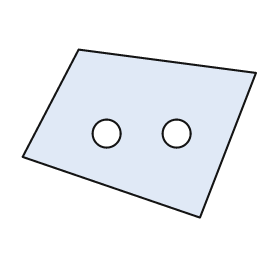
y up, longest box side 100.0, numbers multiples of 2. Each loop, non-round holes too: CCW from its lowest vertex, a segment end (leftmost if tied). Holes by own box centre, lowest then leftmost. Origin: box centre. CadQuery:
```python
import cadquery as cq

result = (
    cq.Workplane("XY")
    .moveTo(26.0, -36.0)
    .lineTo(50.0, 26.0)
    .lineTo(-26.0, 36.0)
    .lineTo(-50.0, -10.0)
    .close()
    .moveTo(-14.0, 0.0)
    .circle(6.0)
    .moveTo(16.0, 0.0)
    .circle(6.0)
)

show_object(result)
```